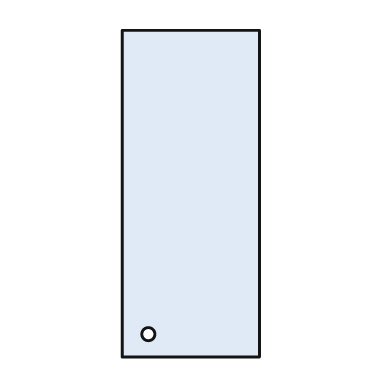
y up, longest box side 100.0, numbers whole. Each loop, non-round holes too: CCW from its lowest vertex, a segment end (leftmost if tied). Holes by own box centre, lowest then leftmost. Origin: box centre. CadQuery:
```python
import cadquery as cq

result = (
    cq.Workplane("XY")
    .moveTo(-21.0, -50.0)
    .lineTo(21.0, -50.0)
    .lineTo(21.0, 50.0)
    .lineTo(-21.0, 50.0)
    .close()
    .moveTo(-13.0, -43.0)
    .circle(2.0)
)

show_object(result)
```